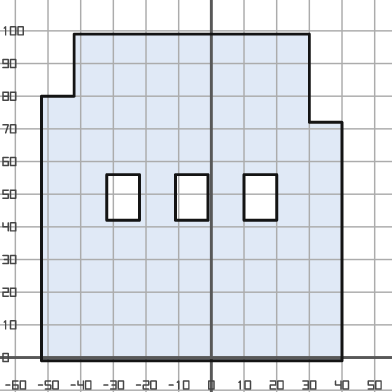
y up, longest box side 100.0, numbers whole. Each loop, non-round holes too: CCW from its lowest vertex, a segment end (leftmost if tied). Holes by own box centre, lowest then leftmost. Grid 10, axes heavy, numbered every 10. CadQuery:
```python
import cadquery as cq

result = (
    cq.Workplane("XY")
    .moveTo(-52.0, -1.0)
    .lineTo(40.0, -1.0)
    .lineTo(40.0, 72.0)
    .lineTo(30.0, 72.0)
    .lineTo(30.0, 99.0)
    .lineTo(-42.0, 99.0)
    .lineTo(-42.0, 80.0)
    .lineTo(-52.0, 80.0)
    .close()
    .moveTo(-32.0, 42.0)
    .lineTo(-22.0, 42.0)
    .lineTo(-22.0, 56.0)
    .lineTo(-32.0, 56.0)
    .close()
    .moveTo(-11.0, 42.0)
    .lineTo(-1.0, 42.0)
    .lineTo(-1.0, 56.0)
    .lineTo(-11.0, 56.0)
    .close()
    .moveTo(10.0, 42.0)
    .lineTo(20.0, 42.0)
    .lineTo(20.0, 56.0)
    .lineTo(10.0, 56.0)
    .close()
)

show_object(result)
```